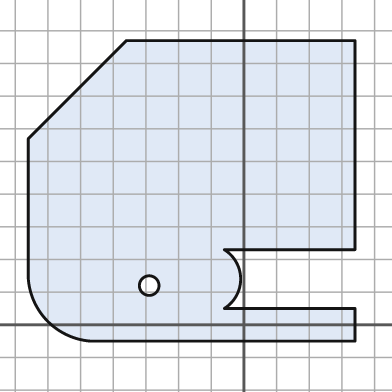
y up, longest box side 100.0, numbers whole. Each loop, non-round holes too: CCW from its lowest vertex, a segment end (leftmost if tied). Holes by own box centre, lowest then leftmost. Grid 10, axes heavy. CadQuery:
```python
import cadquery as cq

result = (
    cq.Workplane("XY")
    .moveTo(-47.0, -5.0)
    .lineTo(34.0, -5.0)
    .lineTo(34.0, 5.0)
    .lineTo(-6.0, 5.0)
    .threePointArc((-1.0, 14.0), (-6.0, 23.0))
    .lineTo(34.0, 23.0)
    .lineTo(34.0, 87.0)
    .lineTo(-36.0, 87.0)
    .lineTo(-66.0, 57.0)
    .lineTo(-66.0, 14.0)
    .threePointArc((-60.0, 1.0), (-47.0, -5.0))
    .close()
    .moveTo(-29.0, 12.0)
    .circle(3.0)
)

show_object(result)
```